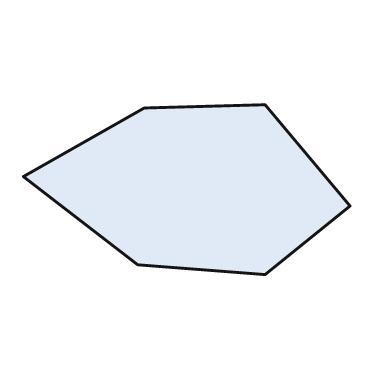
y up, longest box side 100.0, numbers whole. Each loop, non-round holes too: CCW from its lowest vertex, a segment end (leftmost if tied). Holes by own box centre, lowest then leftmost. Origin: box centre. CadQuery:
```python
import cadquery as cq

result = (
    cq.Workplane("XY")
    .moveTo(24.0, -26.0)
    .lineTo(50.0, -5.0)
    .lineTo(24.0, 26.0)
    .lineTo(-13.0, 25.0)
    .lineTo(-50.0, 4.0)
    .lineTo(-15.0, -23.0)
    .close()
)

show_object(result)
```